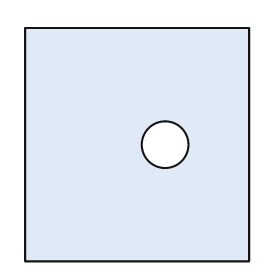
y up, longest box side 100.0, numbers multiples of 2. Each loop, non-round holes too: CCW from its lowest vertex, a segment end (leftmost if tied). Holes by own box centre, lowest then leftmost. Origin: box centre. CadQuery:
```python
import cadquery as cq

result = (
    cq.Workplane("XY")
    .moveTo(-48.0, -50.0)
    .lineTo(48.0, -50.0)
    .lineTo(48.0, 50.0)
    .lineTo(-48.0, 50.0)
    .close()
    .moveTo(12.0, 0.0)
    .circle(10.0)
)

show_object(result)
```